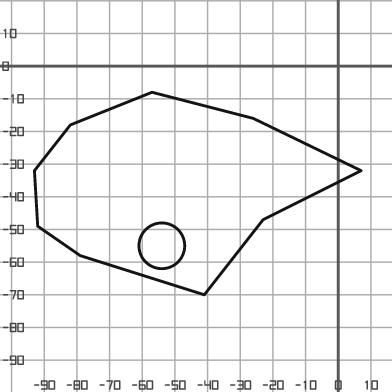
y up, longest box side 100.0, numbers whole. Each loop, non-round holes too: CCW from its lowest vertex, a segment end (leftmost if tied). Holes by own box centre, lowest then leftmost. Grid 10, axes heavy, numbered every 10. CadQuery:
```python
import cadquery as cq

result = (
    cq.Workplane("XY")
    .moveTo(-41.0, -70.0)
    .lineTo(-23.0, -47.0)
    .lineTo(7.0, -32.0)
    .lineTo(-26.0, -16.0)
    .lineTo(-57.0, -8.0)
    .lineTo(-82.0, -18.0)
    .lineTo(-93.0, -32.0)
    .lineTo(-92.0, -49.0)
    .lineTo(-79.0, -58.0)
    .close()
    .moveTo(-54.0, -55.0)
    .circle(7.0)
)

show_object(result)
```